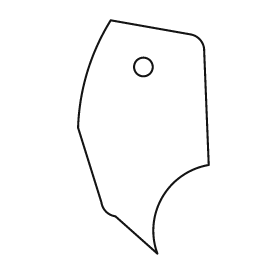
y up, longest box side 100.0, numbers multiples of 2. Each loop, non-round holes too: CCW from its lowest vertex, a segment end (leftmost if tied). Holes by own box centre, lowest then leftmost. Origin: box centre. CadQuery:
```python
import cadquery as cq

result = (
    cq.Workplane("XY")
    .moveTo(6.0, -50.0)
    .threePointArc((8.0, -26.0), (28.0, -12.0))
    .lineTo(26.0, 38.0)
    .threePointArc((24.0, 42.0), (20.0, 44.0))
    .lineTo(-14.0, 50.0)
    .threePointArc((-24.0, 28.0), (-28.0, 4.0))
    .lineTo(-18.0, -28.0)
    .threePointArc((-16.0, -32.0), (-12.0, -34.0))
    .close()
    .moveTo(0.0, 30.0)
    .circle(4.0)
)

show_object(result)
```